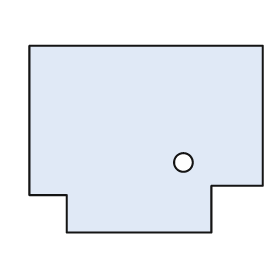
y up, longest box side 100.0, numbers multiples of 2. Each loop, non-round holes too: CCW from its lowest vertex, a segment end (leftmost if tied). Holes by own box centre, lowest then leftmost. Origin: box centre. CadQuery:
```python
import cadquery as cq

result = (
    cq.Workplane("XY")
    .moveTo(-34.0, -40.0)
    .lineTo(28.0, -40.0)
    .lineTo(28.0, -20.0)
    .lineTo(50.0, -20.0)
    .lineTo(50.0, 40.0)
    .lineTo(-50.0, 40.0)
    .lineTo(-50.0, -24.0)
    .lineTo(-34.0, -24.0)
    .close()
    .moveTo(16.0, -10.0)
    .circle(4.0)
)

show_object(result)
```